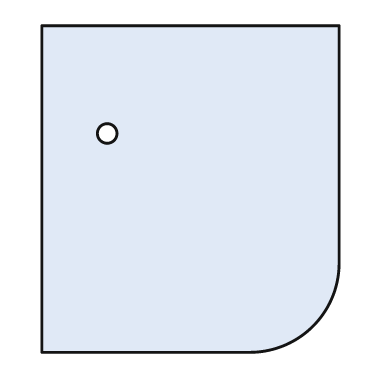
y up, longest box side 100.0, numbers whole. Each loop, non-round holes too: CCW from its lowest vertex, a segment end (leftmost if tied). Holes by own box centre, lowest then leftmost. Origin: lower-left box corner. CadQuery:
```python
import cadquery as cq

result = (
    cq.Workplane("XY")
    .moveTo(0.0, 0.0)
    .lineTo(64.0, 0.0)
    .threePointArc((83.0, 8.0), (91.0, 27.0))
    .lineTo(91.0, 100.0)
    .lineTo(0.0, 100.0)
    .close()
    .moveTo(20.0, 67.0)
    .circle(3.0)
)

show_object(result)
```